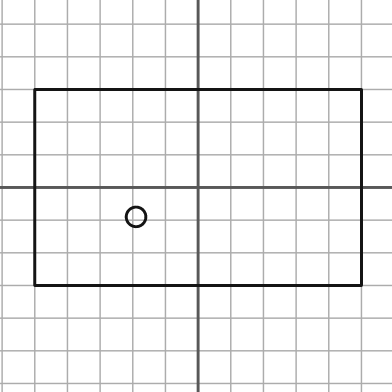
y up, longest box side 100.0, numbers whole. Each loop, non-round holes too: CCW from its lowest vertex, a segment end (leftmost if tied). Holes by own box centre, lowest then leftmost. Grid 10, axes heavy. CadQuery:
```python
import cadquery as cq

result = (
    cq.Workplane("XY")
    .moveTo(-50.0, -30.0)
    .lineTo(50.0, -30.0)
    .lineTo(50.0, 30.0)
    .lineTo(-50.0, 30.0)
    .close()
    .moveTo(-19.0, -9.0)
    .circle(3.0)
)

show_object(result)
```